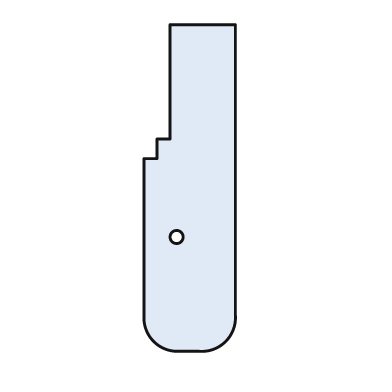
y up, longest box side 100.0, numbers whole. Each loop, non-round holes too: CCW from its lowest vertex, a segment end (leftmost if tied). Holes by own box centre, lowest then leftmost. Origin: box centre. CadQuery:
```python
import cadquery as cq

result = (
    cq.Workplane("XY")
    .moveTo(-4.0, -50.0)
    .lineTo(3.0, -50.0)
    .threePointArc((11.0, -47.0), (14.0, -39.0))
    .lineTo(14.0, 50.0)
    .lineTo(-6.0, 50.0)
    .lineTo(-6.0, 15.0)
    .lineTo(-10.0, 15.0)
    .lineTo(-10.0, 9.0)
    .lineTo(-14.0, 9.0)
    .lineTo(-14.0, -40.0)
    .threePointArc((-11.0, -47.0), (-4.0, -50.0))
    .close()
    .moveTo(-4.0, -15.0)
    .circle(2.0)
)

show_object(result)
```